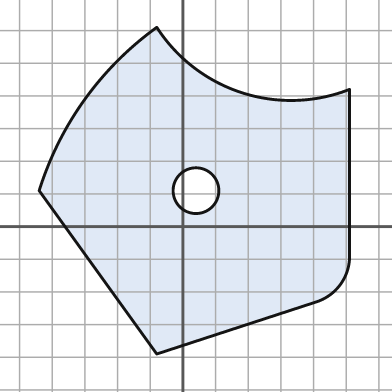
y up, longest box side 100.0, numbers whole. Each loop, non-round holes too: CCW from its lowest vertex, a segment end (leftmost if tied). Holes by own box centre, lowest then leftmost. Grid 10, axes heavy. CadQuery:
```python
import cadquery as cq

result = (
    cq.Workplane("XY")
    .moveTo(-8.0, -39.0)
    .lineTo(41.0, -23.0)
    .threePointArc((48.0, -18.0), (51.0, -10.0))
    .lineTo(51.0, 42.0)
    .threePointArc((18.0, 41.0), (-8.0, 61.0))
    .threePointArc((-30.0, 39.0), (-44.0, 11.0))
    .close()
    .moveTo(4.0, 11.0)
    .circle(7.0)
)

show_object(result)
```